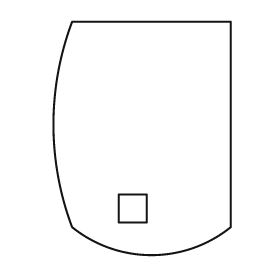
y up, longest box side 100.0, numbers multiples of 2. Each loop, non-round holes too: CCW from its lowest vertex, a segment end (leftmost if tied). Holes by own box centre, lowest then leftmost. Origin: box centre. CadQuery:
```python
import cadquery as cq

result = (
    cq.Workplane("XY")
    .moveTo(-30.0, -38.0)
    .threePointArc((4.0, -50.0), (38.0, -38.0))
    .lineTo(38.0, 50.0)
    .lineTo(-30.0, 50.0)
    .threePointArc((-38.0, 6.0), (-30.0, -38.0))
    .close()
    .moveTo(-10.0, -36.0)
    .lineTo(2.0, -36.0)
    .lineTo(2.0, -24.0)
    .lineTo(-10.0, -24.0)
    .close()
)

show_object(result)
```